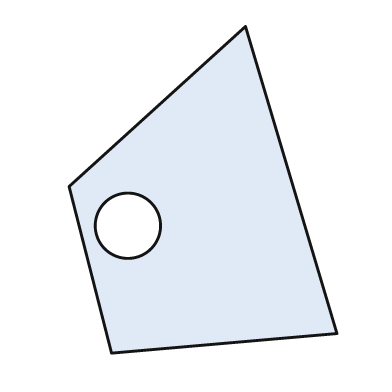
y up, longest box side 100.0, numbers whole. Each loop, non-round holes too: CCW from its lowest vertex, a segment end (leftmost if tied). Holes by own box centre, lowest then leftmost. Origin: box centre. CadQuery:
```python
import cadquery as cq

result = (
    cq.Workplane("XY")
    .moveTo(-28.0, -50.0)
    .lineTo(41.0, -44.0)
    .lineTo(13.0, 50.0)
    .lineTo(-41.0, 1.0)
    .close()
    .moveTo(-23.0, -11.0)
    .circle(10.0)
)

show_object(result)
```